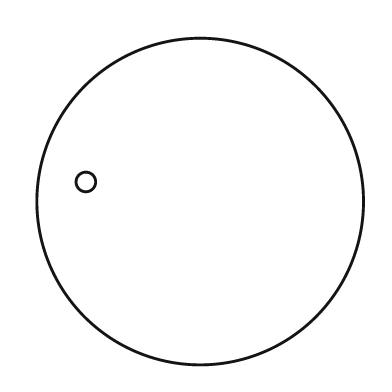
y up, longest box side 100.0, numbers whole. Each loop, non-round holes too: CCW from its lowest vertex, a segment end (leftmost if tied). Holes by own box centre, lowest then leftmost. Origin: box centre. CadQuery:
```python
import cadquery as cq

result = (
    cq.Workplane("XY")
    .moveTo(0.0, 0.0)
    .circle(50.0)
    .moveTo(-35.0, 6.0)
    .circle(3.0)
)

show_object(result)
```